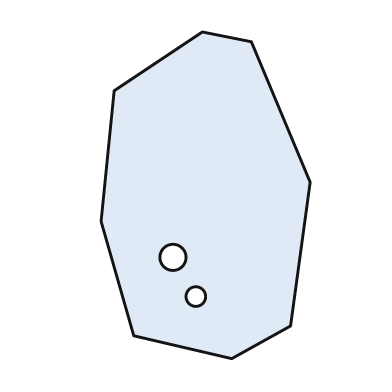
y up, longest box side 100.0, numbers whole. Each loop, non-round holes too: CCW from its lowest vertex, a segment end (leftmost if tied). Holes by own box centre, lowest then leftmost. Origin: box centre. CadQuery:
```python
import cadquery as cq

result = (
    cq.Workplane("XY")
    .moveTo(8.0, -50.0)
    .lineTo(26.0, -40.0)
    .lineTo(32.0, 4.0)
    .lineTo(14.0, 47.0)
    .lineTo(-1.0, 50.0)
    .lineTo(-28.0, 32.0)
    .lineTo(-32.0, -8.0)
    .lineTo(-22.0, -43.0)
    .close()
    .moveTo(-3.0, -31.0)
    .circle(3.0)
    .moveTo(-10.0, -19.0)
    .circle(4.0)
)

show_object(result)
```